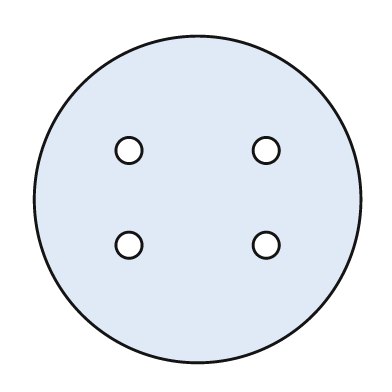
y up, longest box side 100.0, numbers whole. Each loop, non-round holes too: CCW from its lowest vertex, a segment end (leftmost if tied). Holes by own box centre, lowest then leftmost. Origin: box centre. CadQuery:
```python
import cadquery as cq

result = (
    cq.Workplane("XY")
    .moveTo(0.0, 0.0)
    .circle(50.0)
    .moveTo(-21.0, -14.0)
    .circle(4.0)
    .moveTo(21.0, -14.0)
    .circle(4.0)
    .moveTo(-21.0, 15.0)
    .circle(4.0)
    .moveTo(21.0, 15.0)
    .circle(4.0)
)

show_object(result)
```